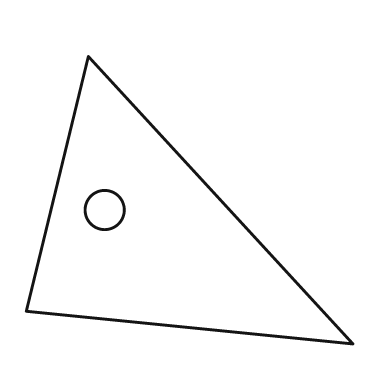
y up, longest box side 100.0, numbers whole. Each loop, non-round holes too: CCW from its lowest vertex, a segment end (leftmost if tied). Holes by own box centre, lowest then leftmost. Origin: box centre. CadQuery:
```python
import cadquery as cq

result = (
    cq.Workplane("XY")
    .moveTo(50.0, -44.0)
    .lineTo(-31.0, 44.0)
    .lineTo(-50.0, -34.0)
    .close()
    .moveTo(-26.0, -3.0)
    .circle(6.0)
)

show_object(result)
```